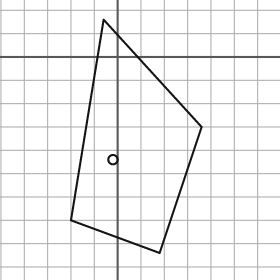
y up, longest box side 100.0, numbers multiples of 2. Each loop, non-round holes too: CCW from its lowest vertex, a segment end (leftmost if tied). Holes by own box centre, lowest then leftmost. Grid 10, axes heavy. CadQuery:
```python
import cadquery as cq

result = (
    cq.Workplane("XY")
    .moveTo(18.0, -84.0)
    .lineTo(36.0, -30.0)
    .lineTo(-6.0, 16.0)
    .lineTo(-20.0, -70.0)
    .close()
    .moveTo(-2.0, -44.0)
    .circle(2.0)
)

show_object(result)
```